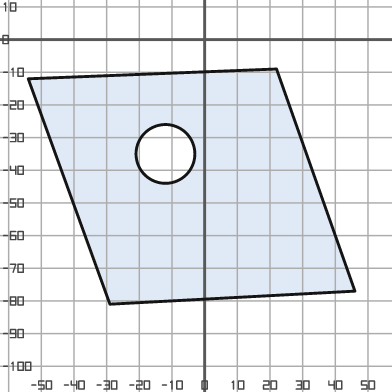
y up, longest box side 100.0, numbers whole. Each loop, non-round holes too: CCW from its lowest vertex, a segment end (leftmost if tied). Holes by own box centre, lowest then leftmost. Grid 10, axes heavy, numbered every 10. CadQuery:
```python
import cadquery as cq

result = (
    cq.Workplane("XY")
    .moveTo(-29.0, -81.0)
    .lineTo(46.0, -77.0)
    .lineTo(22.0, -9.0)
    .lineTo(-54.0, -12.0)
    .close()
    .moveTo(-12.0, -35.0)
    .circle(9.0)
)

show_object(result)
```